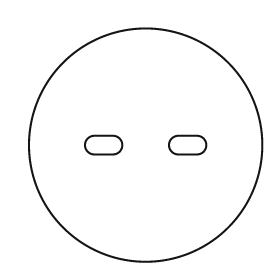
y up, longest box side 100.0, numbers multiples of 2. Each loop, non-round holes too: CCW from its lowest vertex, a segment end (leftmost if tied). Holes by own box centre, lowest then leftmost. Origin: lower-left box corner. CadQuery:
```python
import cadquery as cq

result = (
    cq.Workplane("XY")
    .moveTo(50.0, 50.0)
    .circle(50.0)
    .moveTo(28.0, 46.0)
    .lineTo(36.0, 46.0)
    .threePointArc((40.0, 50.0), (36.0, 54.0))
    .lineTo(28.0, 54.0)
    .threePointArc((24.0, 50.0), (28.0, 46.0))
    .close()
    .moveTo(64.0, 46.0)
    .lineTo(72.0, 46.0)
    .threePointArc((76.0, 50.0), (72.0, 54.0))
    .lineTo(64.0, 54.0)
    .threePointArc((60.0, 50.0), (64.0, 46.0))
    .close()
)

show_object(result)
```